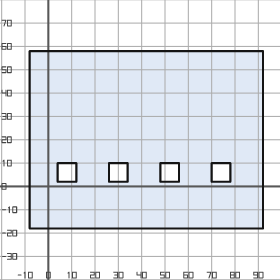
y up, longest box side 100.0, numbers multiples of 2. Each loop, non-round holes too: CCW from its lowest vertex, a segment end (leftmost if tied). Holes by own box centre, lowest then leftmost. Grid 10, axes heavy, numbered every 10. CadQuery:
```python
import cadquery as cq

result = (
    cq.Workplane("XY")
    .moveTo(-8.0, -18.0)
    .lineTo(92.0, -18.0)
    .lineTo(92.0, 58.0)
    .lineTo(-8.0, 58.0)
    .close()
    .moveTo(4.0, 2.0)
    .lineTo(12.0, 2.0)
    .lineTo(12.0, 10.0)
    .lineTo(4.0, 10.0)
    .close()
    .moveTo(26.0, 2.0)
    .lineTo(34.0, 2.0)
    .lineTo(34.0, 10.0)
    .lineTo(26.0, 10.0)
    .close()
    .moveTo(48.0, 2.0)
    .lineTo(56.0, 2.0)
    .lineTo(56.0, 10.0)
    .lineTo(48.0, 10.0)
    .close()
    .moveTo(70.0, 2.0)
    .lineTo(78.0, 2.0)
    .lineTo(78.0, 10.0)
    .lineTo(70.0, 10.0)
    .close()
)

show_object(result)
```